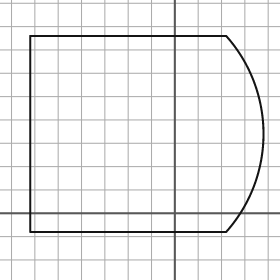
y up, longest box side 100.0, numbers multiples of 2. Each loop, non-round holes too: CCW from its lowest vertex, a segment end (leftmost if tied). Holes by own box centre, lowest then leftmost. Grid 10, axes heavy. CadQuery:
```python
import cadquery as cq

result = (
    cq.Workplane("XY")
    .moveTo(-62.0, -8.0)
    .lineTo(22.0, -8.0)
    .threePointArc((38.0, 34.0), (22.0, 76.0))
    .lineTo(-62.0, 76.0)
    .close()
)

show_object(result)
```